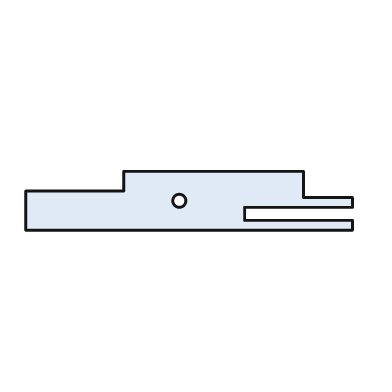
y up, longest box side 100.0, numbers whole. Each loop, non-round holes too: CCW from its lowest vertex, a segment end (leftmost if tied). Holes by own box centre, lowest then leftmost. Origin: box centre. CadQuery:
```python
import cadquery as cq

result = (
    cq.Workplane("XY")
    .moveTo(-50.0, -9.0)
    .lineTo(50.0, -9.0)
    .lineTo(50.0, -6.0)
    .lineTo(17.0, -6.0)
    .lineTo(17.0, -2.0)
    .lineTo(50.0, -2.0)
    .lineTo(50.0, 1.0)
    .lineTo(35.0, 1.0)
    .lineTo(35.0, 9.0)
    .lineTo(-20.0, 9.0)
    .lineTo(-20.0, 3.0)
    .lineTo(-50.0, 3.0)
    .close()
    .moveTo(-3.0, 0.0)
    .circle(2.0)
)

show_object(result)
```